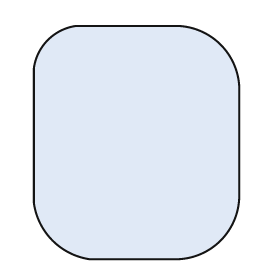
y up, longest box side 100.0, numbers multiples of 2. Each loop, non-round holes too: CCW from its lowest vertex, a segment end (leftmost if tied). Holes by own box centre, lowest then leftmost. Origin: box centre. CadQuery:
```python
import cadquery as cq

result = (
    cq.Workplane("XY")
    .moveTo(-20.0, -50.0)
    .lineTo(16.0, -50.0)
    .threePointArc((36.0, -42.0), (44.0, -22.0))
    .lineTo(44.0, 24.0)
    .threePointArc((36.0, 42.0), (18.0, 50.0))
    .lineTo(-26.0, 50.0)
    .threePointArc((-38.0, 44.0), (-44.0, 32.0))
    .lineTo(-44.0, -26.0)
    .threePointArc((-36.0, -42.0), (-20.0, -50.0))
    .close()
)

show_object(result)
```